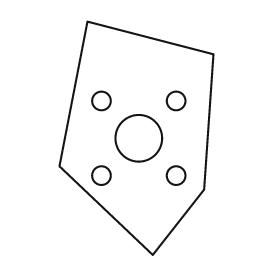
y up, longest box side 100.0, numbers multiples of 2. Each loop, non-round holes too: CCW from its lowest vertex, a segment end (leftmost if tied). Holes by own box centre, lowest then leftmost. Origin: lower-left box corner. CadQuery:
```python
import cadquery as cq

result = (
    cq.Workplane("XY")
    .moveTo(40.0, 0.0)
    .lineTo(62.0, 28.0)
    .lineTo(66.0, 86.0)
    .lineTo(12.0, 100.0)
    .lineTo(0.0, 38.0)
    .close()
    .moveTo(18.0, 34.0)
    .circle(4.0)
    .moveTo(50.0, 34.0)
    .circle(4.0)
    .moveTo(34.0, 50.0)
    .circle(10.0)
    .moveTo(18.0, 66.0)
    .circle(4.0)
    .moveTo(50.0, 66.0)
    .circle(4.0)
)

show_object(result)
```